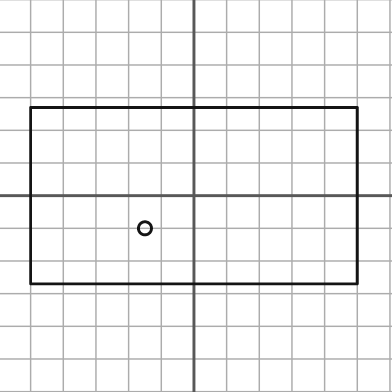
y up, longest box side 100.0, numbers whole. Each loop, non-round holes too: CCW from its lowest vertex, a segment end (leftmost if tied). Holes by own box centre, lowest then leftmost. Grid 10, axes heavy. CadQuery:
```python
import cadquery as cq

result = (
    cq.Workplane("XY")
    .moveTo(-50.0, -27.0)
    .lineTo(50.0, -27.0)
    .lineTo(50.0, 27.0)
    .lineTo(-50.0, 27.0)
    .close()
    .moveTo(-15.0, -10.0)
    .circle(2.0)
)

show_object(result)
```